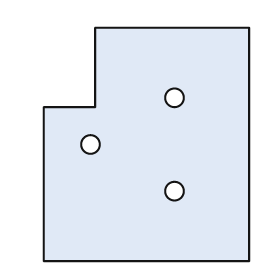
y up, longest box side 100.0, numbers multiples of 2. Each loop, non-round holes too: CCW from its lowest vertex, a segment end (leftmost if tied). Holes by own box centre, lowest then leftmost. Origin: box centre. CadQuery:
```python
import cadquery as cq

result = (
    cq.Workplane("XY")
    .moveTo(-44.0, -50.0)
    .lineTo(44.0, -50.0)
    .lineTo(44.0, 50.0)
    .lineTo(-22.0, 50.0)
    .lineTo(-22.0, 16.0)
    .lineTo(-44.0, 16.0)
    .close()
    .moveTo(12.0, -20.0)
    .circle(4.0)
    .moveTo(-24.0, 0.0)
    .circle(4.0)
    .moveTo(12.0, 20.0)
    .circle(4.0)
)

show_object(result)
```